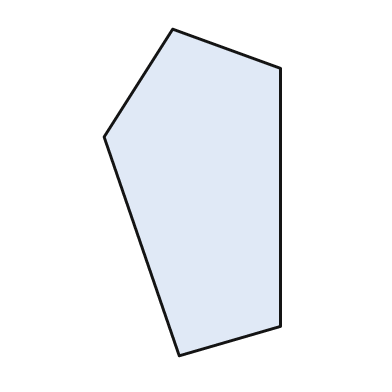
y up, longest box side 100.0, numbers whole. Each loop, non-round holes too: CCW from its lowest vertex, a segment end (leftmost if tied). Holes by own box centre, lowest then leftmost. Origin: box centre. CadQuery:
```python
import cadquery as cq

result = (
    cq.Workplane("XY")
    .moveTo(-4.0, -50.0)
    .lineTo(27.0, -41.0)
    .lineTo(27.0, 38.0)
    .lineTo(-6.0, 50.0)
    .lineTo(-27.0, 17.0)
    .close()
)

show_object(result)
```